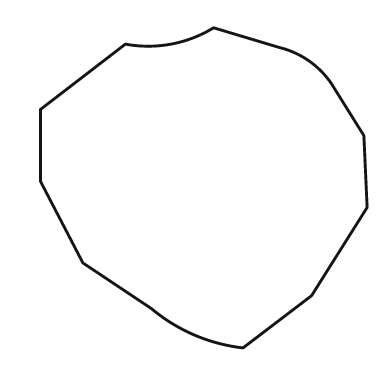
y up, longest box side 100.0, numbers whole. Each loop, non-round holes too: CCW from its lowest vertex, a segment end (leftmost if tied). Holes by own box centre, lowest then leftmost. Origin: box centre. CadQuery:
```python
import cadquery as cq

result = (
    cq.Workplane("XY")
    .moveTo(12.0, -49.0)
    .lineTo(33.0, -33.0)
    .lineTo(50.0, -6.0)
    .lineTo(49.0, 16.0)
    .lineTo(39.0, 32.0)
    .threePointArc((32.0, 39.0), (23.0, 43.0))
    .lineTo(3.0, 49.0)
    .threePointArc((-10.0, 44.0), (-24.0, 44.0))
    .lineTo(-50.0, 24.0)
    .lineTo(-50.0, 2.0)
    .lineTo(-37.0, -23.0)
    .lineTo(-16.0, -37.0)
    .threePointArc((-3.0, -45.0), (12.0, -49.0))
    .close()
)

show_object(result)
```